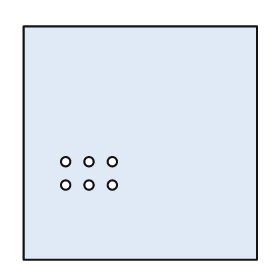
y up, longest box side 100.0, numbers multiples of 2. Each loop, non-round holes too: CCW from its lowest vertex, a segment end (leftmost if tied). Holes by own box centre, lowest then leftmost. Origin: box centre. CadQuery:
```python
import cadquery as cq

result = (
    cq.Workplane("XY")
    .moveTo(-50.0, -50.0)
    .lineTo(50.0, -50.0)
    .lineTo(50.0, 50.0)
    .lineTo(-50.0, 50.0)
    .close()
    .moveTo(-32.0, -18.0)
    .circle(2.0)
    .moveTo(-22.0, -18.0)
    .circle(2.0)
    .moveTo(-12.0, -18.0)
    .circle(2.0)
    .moveTo(-32.0, -8.0)
    .circle(2.0)
    .moveTo(-22.0, -8.0)
    .circle(2.0)
    .moveTo(-12.0, -8.0)
    .circle(2.0)
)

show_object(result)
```